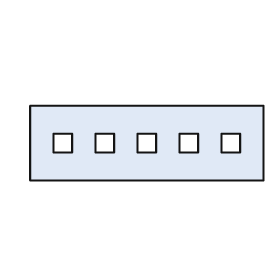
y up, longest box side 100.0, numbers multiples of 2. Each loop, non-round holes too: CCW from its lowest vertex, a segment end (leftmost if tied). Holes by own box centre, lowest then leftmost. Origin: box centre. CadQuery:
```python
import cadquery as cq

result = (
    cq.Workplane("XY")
    .moveTo(-50.0, -16.0)
    .lineTo(50.0, -16.0)
    .lineTo(50.0, 16.0)
    .lineTo(-50.0, 16.0)
    .close()
    .moveTo(-40.0, -4.0)
    .lineTo(-32.0, -4.0)
    .lineTo(-32.0, 4.0)
    .lineTo(-40.0, 4.0)
    .close()
    .moveTo(-22.0, -4.0)
    .lineTo(-14.0, -4.0)
    .lineTo(-14.0, 4.0)
    .lineTo(-22.0, 4.0)
    .close()
    .moveTo(-4.0, -4.0)
    .lineTo(4.0, -4.0)
    .lineTo(4.0, 4.0)
    .lineTo(-4.0, 4.0)
    .close()
    .moveTo(14.0, -4.0)
    .lineTo(22.0, -4.0)
    .lineTo(22.0, 4.0)
    .lineTo(14.0, 4.0)
    .close()
    .moveTo(32.0, -4.0)
    .lineTo(40.0, -4.0)
    .lineTo(40.0, 4.0)
    .lineTo(32.0, 4.0)
    .close()
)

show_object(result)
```